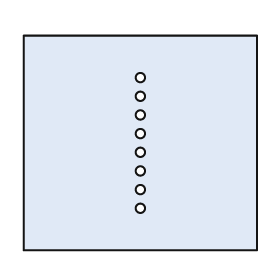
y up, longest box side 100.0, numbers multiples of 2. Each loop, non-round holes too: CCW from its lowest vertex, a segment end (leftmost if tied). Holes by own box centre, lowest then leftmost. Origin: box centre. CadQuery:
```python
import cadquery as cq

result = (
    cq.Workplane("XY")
    .moveTo(-50.0, -46.0)
    .lineTo(50.0, -46.0)
    .lineTo(50.0, 46.0)
    .lineTo(-50.0, 46.0)
    .close()
    .moveTo(0.0, -28.0)
    .circle(2.0)
    .moveTo(0.0, -20.0)
    .circle(2.0)
    .moveTo(0.0, -12.0)
    .circle(2.0)
    .moveTo(0.0, -4.0)
    .circle(2.0)
    .moveTo(0.0, 4.0)
    .circle(2.0)
    .moveTo(0.0, 12.0)
    .circle(2.0)
    .moveTo(0.0, 20.0)
    .circle(2.0)
    .moveTo(0.0, 28.0)
    .circle(2.0)
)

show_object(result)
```